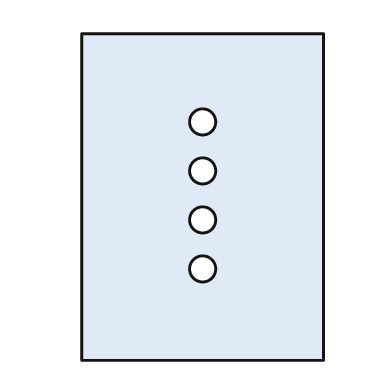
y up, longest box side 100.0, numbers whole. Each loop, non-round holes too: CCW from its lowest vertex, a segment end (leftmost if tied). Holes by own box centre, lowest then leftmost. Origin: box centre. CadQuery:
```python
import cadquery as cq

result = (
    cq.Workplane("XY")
    .moveTo(-37.0, -50.0)
    .lineTo(37.0, -50.0)
    .lineTo(37.0, 50.0)
    .lineTo(-37.0, 50.0)
    .close()
    .moveTo(0.0, -22.0)
    .circle(4.0)
    .moveTo(0.0, -7.0)
    .circle(4.0)
    .moveTo(0.0, 8.0)
    .circle(4.0)
    .moveTo(0.0, 23.0)
    .circle(4.0)
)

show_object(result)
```